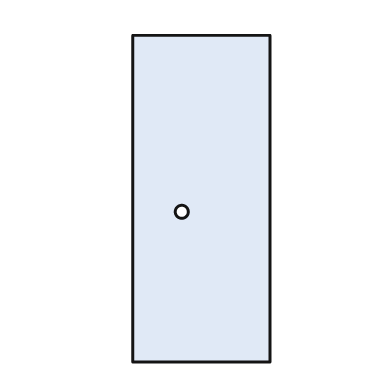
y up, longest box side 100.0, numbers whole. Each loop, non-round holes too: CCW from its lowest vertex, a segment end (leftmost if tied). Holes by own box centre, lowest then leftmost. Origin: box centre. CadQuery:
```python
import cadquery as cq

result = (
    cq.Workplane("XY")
    .moveTo(-21.0, -50.0)
    .lineTo(21.0, -50.0)
    .lineTo(21.0, 50.0)
    .lineTo(-21.0, 50.0)
    .close()
    .moveTo(-6.0, -4.0)
    .circle(2.0)
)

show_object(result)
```